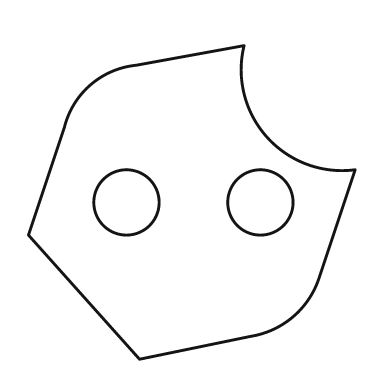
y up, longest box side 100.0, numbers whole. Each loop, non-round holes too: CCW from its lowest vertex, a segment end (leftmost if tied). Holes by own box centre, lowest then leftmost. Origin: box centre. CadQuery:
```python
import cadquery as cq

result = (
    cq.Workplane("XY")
    .moveTo(-16.0, -48.0)
    .lineTo(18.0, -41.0)
    .threePointArc((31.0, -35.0), (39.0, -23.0))
    .lineTo(50.0, 10.0)
    .threePointArc((23.0, 20.0), (16.0, 48.0))
    .lineTo(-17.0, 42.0)
    .threePointArc((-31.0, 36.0), (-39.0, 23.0))
    .lineTo(-50.0, -10.0)
    .close()
    .moveTo(-20.0, 0.0)
    .circle(10.0)
    .moveTo(21.0, 0.0)
    .circle(10.0)
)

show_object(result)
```